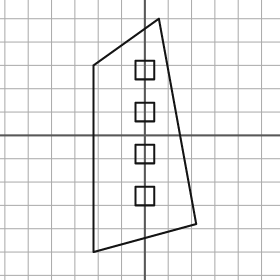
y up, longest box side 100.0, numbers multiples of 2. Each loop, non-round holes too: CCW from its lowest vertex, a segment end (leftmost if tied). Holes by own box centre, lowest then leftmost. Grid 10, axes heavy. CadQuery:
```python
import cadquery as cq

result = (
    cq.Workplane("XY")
    .moveTo(-22.0, -50.0)
    .lineTo(22.0, -38.0)
    .lineTo(6.0, 50.0)
    .lineTo(-22.0, 30.0)
    .close()
    .moveTo(-4.0, -30.0)
    .lineTo(4.0, -30.0)
    .lineTo(4.0, -22.0)
    .lineTo(-4.0, -22.0)
    .close()
    .moveTo(-4.0, -12.0)
    .lineTo(4.0, -12.0)
    .lineTo(4.0, -4.0)
    .lineTo(-4.0, -4.0)
    .close()
    .moveTo(-4.0, 6.0)
    .lineTo(4.0, 6.0)
    .lineTo(4.0, 14.0)
    .lineTo(-4.0, 14.0)
    .close()
    .moveTo(-4.0, 24.0)
    .lineTo(4.0, 24.0)
    .lineTo(4.0, 32.0)
    .lineTo(-4.0, 32.0)
    .close()
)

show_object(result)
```